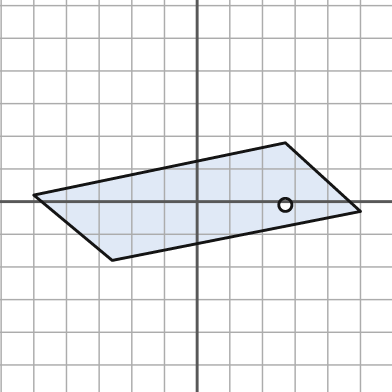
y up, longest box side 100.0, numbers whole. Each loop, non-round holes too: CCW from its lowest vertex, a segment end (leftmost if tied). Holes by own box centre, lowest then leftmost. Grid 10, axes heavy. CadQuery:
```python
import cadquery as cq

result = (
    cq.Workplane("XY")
    .moveTo(-26.0, -18.0)
    .lineTo(50.0, -3.0)
    .lineTo(27.0, 18.0)
    .lineTo(-50.0, 2.0)
    .close()
    .moveTo(27.0, -1.0)
    .circle(2.0)
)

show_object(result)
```